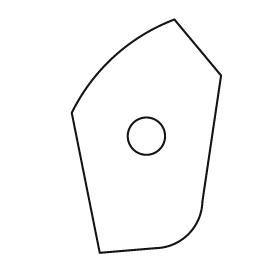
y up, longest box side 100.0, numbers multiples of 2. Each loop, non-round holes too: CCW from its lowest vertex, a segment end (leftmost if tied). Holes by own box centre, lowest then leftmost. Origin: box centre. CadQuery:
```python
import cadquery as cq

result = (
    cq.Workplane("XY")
    .moveTo(-20.0, -50.0)
    .lineTo(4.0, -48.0)
    .threePointArc((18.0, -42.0), (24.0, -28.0))
    .lineTo(32.0, 26.0)
    .lineTo(12.0, 50.0)
    .threePointArc((-14.0, 34.0), (-32.0, 10.0))
    .close()
    .moveTo(0.0, 0.0)
    .circle(8.0)
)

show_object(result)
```